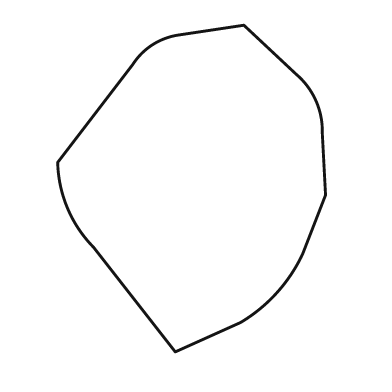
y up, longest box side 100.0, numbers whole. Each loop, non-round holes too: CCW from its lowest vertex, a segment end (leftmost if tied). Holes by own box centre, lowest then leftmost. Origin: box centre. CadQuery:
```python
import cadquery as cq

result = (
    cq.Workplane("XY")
    .moveTo(-5.0, -50.0)
    .lineTo(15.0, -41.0)
    .threePointArc((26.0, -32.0), (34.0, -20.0))
    .lineTo(41.0, -2.0)
    .lineTo(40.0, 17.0)
    .threePointArc((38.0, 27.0), (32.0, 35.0))
    .lineTo(16.0, 50.0)
    .lineTo(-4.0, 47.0)
    .threePointArc((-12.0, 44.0), (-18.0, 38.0))
    .lineTo(-41.0, 8.0)
    .threePointArc((-38.0, -6.0), (-30.0, -18.0))
    .close()
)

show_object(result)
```